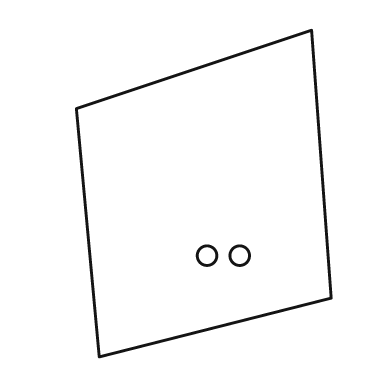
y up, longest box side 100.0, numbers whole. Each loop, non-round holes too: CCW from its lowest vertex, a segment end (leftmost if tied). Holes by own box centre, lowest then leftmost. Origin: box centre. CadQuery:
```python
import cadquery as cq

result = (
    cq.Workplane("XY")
    .moveTo(-32.0, -50.0)
    .lineTo(39.0, -32.0)
    .lineTo(33.0, 50.0)
    .lineTo(-39.0, 26.0)
    .close()
    .moveTo(1.0, -19.0)
    .circle(3.0)
    .moveTo(11.0, -19.0)
    .circle(3.0)
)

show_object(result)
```